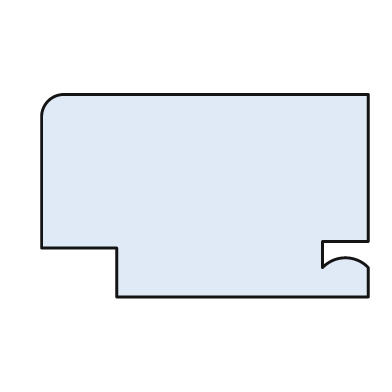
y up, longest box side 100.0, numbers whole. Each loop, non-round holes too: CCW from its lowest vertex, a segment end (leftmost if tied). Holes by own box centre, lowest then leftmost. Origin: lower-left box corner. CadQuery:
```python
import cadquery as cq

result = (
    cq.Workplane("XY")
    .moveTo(23.0, 0.0)
    .lineTo(100.0, 0.0)
    .lineTo(100.0, 9.0)
    .threePointArc((93.0, 12.0), (86.0, 9.0))
    .lineTo(86.0, 17.0)
    .lineTo(100.0, 17.0)
    .lineTo(100.0, 62.0)
    .lineTo(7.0, 62.0)
    .threePointArc((2.0, 60.0), (0.0, 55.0))
    .lineTo(0.0, 15.0)
    .lineTo(23.0, 15.0)
    .close()
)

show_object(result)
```